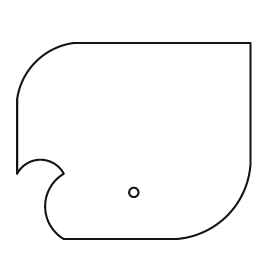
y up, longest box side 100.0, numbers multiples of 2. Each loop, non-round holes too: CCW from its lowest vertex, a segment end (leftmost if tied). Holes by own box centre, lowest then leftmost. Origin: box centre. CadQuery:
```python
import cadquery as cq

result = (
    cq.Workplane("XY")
    .moveTo(-30.0, -42.0)
    .lineTo(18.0, -42.0)
    .threePointArc((40.0, -32.0), (50.0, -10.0))
    .lineTo(50.0, 42.0)
    .lineTo(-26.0, 42.0)
    .threePointArc((-42.0, 34.0), (-50.0, 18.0))
    .lineTo(-50.0, -14.0)
    .threePointArc((-40.0, -8.0), (-30.0, -14.0))
    .threePointArc((-38.0, -28.0), (-30.0, -42.0))
    .close()
    .moveTo(0.0, -22.0)
    .circle(2.0)
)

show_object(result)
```